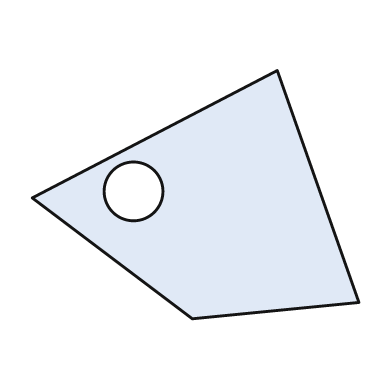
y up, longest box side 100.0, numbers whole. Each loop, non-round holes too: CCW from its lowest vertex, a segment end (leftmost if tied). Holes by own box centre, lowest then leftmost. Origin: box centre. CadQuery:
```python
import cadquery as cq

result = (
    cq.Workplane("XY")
    .moveTo(-1.0, -38.0)
    .lineTo(50.0, -33.0)
    .lineTo(25.0, 38.0)
    .lineTo(-50.0, -1.0)
    .close()
    .moveTo(-19.0, 1.0)
    .circle(9.0)
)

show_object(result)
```